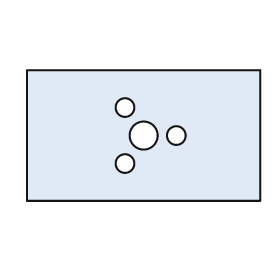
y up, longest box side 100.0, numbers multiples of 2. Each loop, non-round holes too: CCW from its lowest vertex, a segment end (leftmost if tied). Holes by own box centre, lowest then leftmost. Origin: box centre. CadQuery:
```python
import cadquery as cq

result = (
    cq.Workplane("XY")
    .moveTo(-50.0, -28.0)
    .lineTo(50.0, -28.0)
    .lineTo(50.0, 28.0)
    .lineTo(-50.0, 28.0)
    .close()
    .moveTo(-8.0, -12.0)
    .circle(4.0)
    .moveTo(0.0, 0.0)
    .circle(6.0)
    .moveTo(14.0, 0.0)
    .circle(4.0)
    .moveTo(-8.0, 12.0)
    .circle(4.0)
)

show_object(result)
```